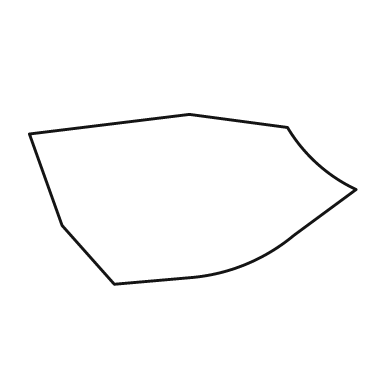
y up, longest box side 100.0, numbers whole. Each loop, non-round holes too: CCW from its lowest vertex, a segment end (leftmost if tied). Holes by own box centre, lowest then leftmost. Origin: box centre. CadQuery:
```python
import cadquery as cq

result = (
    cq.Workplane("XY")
    .moveTo(-24.0, -26.0)
    .lineTo(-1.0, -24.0)
    .threePointArc((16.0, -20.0), (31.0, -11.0))
    .lineTo(50.0, 3.0)
    .threePointArc((38.0, 11.0), (29.0, 22.0))
    .lineTo(-1.0, 26.0)
    .lineTo(-50.0, 20.0)
    .lineTo(-40.0, -8.0)
    .close()
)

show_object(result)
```